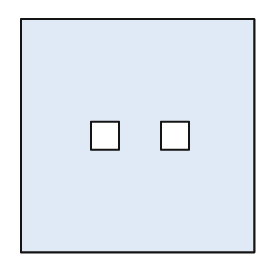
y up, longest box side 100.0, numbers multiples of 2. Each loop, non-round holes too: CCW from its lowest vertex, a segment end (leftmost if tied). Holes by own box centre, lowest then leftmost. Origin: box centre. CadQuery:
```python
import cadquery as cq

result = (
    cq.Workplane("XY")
    .moveTo(-50.0, -50.0)
    .lineTo(50.0, -50.0)
    .lineTo(50.0, 50.0)
    .lineTo(-50.0, 50.0)
    .close()
    .moveTo(-20.0, -6.0)
    .lineTo(-8.0, -6.0)
    .lineTo(-8.0, 6.0)
    .lineTo(-20.0, 6.0)
    .close()
    .moveTo(10.0, -6.0)
    .lineTo(22.0, -6.0)
    .lineTo(22.0, 6.0)
    .lineTo(10.0, 6.0)
    .close()
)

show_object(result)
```